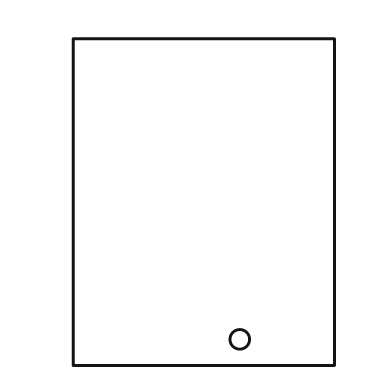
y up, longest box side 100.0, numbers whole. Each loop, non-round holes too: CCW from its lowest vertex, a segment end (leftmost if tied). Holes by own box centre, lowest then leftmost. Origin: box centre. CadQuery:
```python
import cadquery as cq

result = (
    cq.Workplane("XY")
    .moveTo(-40.0, -50.0)
    .lineTo(40.0, -50.0)
    .lineTo(40.0, 50.0)
    .lineTo(-40.0, 50.0)
    .close()
    .moveTo(11.0, -42.0)
    .circle(3.0)
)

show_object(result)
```